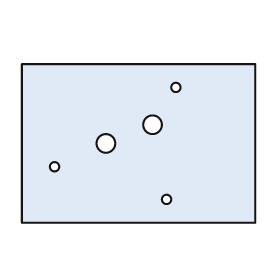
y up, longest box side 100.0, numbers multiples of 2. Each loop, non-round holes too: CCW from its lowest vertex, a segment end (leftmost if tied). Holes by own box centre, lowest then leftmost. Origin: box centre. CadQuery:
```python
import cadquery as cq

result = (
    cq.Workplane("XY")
    .moveTo(-50.0, -34.0)
    .lineTo(50.0, -34.0)
    .lineTo(50.0, 34.0)
    .lineTo(-50.0, 34.0)
    .close()
    .moveTo(12.0, -24.0)
    .circle(2.0)
    .moveTo(-36.0, -10.0)
    .circle(2.0)
    .moveTo(-14.0, 0.0)
    .circle(4.0)
    .moveTo(6.0, 8.0)
    .circle(4.0)
    .moveTo(16.0, 24.0)
    .circle(2.0)
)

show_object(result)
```